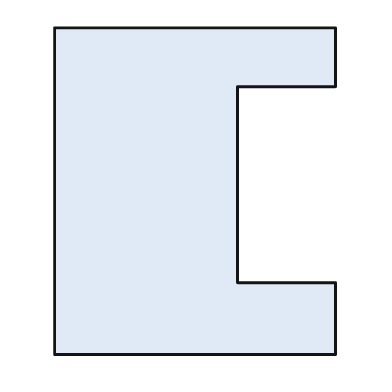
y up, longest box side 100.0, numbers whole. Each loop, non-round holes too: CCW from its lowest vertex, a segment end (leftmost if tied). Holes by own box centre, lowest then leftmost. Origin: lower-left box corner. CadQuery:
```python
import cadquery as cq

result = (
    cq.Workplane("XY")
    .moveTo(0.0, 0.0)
    .lineTo(86.0, 0.0)
    .lineTo(86.0, 22.0)
    .lineTo(56.0, 22.0)
    .lineTo(56.0, 82.0)
    .lineTo(86.0, 82.0)
    .lineTo(86.0, 100.0)
    .lineTo(0.0, 100.0)
    .close()
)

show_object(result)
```